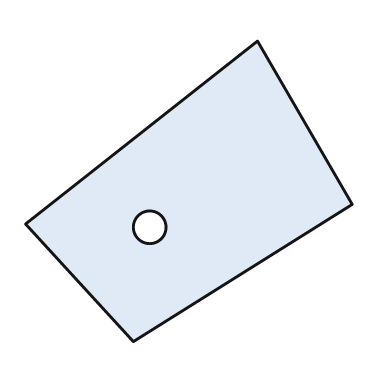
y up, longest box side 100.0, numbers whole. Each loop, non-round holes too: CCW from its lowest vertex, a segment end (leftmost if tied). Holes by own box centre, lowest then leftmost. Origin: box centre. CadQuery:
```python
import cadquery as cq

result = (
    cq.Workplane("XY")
    .moveTo(-17.0, -46.0)
    .lineTo(50.0, -4.0)
    .lineTo(21.0, 46.0)
    .lineTo(-50.0, -10.0)
    .close()
    .moveTo(-12.0, -11.0)
    .circle(5.0)
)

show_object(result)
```